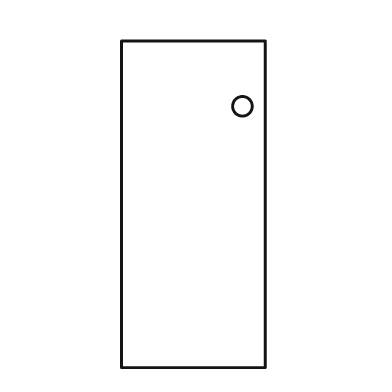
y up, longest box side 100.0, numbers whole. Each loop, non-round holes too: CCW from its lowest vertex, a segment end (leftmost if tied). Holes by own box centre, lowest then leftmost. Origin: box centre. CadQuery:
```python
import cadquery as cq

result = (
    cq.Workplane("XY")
    .moveTo(-22.0, -50.0)
    .lineTo(22.0, -50.0)
    .lineTo(22.0, 50.0)
    .lineTo(-22.0, 50.0)
    .close()
    .moveTo(15.0, 30.0)
    .circle(3.0)
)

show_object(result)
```